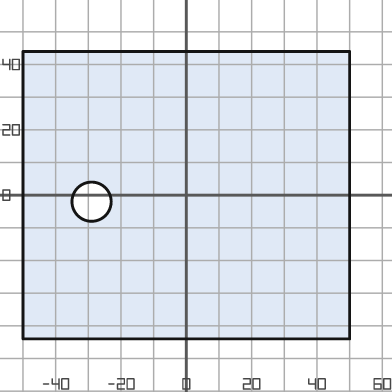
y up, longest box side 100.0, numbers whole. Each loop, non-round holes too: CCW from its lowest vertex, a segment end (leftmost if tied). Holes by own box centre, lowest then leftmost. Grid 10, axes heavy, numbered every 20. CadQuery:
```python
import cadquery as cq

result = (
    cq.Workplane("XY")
    .moveTo(-50.0, -44.0)
    .lineTo(50.0, -44.0)
    .lineTo(50.0, 44.0)
    .lineTo(-50.0, 44.0)
    .close()
    .moveTo(-29.0, -2.0)
    .circle(6.0)
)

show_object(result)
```